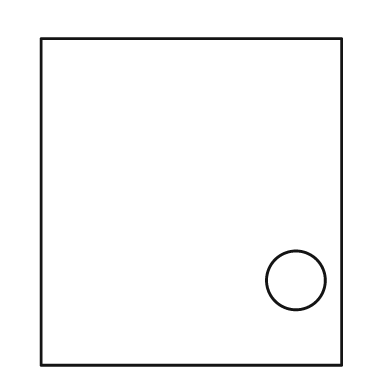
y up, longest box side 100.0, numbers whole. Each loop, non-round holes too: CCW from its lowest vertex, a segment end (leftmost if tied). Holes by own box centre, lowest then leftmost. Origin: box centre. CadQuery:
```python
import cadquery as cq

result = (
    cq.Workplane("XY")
    .moveTo(-46.0, -50.0)
    .lineTo(46.0, -50.0)
    .lineTo(46.0, 50.0)
    .lineTo(-46.0, 50.0)
    .close()
    .moveTo(32.0, -24.0)
    .circle(9.0)
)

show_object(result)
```